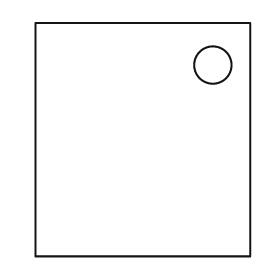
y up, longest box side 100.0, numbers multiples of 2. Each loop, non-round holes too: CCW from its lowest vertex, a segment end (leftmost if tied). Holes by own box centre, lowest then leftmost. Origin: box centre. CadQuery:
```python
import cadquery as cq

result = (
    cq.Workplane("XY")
    .moveTo(-46.0, -50.0)
    .lineTo(46.0, -50.0)
    .lineTo(46.0, 50.0)
    .lineTo(-46.0, 50.0)
    .close()
    .moveTo(30.0, 32.0)
    .circle(8.0)
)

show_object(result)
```